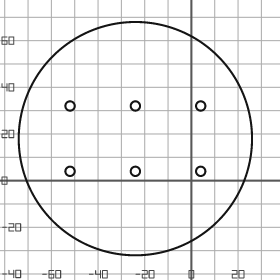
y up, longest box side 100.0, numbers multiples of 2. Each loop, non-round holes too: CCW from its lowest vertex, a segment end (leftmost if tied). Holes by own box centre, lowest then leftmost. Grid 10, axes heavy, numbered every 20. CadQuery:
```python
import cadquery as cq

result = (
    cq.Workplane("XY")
    .moveTo(-24.0, 18.0)
    .circle(50.0)
    .moveTo(-52.0, 4.0)
    .circle(2.0)
    .moveTo(-24.0, 4.0)
    .circle(2.0)
    .moveTo(4.0, 4.0)
    .circle(2.0)
    .moveTo(-52.0, 32.0)
    .circle(2.0)
    .moveTo(-24.0, 32.0)
    .circle(2.0)
    .moveTo(4.0, 32.0)
    .circle(2.0)
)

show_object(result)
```